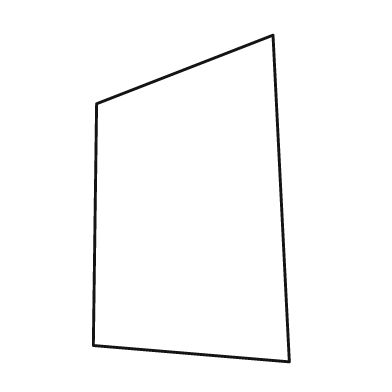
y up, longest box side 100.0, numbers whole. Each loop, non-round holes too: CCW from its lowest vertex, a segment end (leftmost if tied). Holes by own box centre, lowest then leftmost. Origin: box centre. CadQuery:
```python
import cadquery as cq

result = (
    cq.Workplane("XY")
    .moveTo(30.0, -50.0)
    .lineTo(25.0, 50.0)
    .lineTo(-29.0, 29.0)
    .lineTo(-30.0, -45.0)
    .close()
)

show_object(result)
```